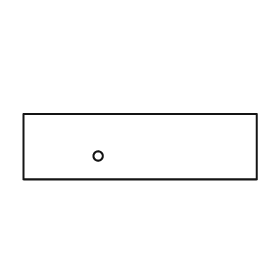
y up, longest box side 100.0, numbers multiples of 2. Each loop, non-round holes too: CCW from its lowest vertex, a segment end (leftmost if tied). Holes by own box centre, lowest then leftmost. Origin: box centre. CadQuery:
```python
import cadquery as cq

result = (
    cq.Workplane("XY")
    .moveTo(-50.0, -14.0)
    .lineTo(50.0, -14.0)
    .lineTo(50.0, 14.0)
    .lineTo(-50.0, 14.0)
    .close()
    .moveTo(-18.0, -4.0)
    .circle(2.0)
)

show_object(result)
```